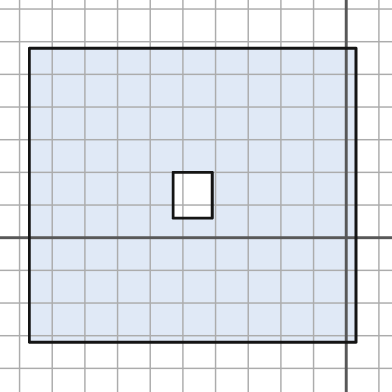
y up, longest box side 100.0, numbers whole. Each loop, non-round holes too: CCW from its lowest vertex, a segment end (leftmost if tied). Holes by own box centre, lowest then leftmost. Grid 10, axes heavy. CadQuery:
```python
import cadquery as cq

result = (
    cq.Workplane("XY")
    .moveTo(-97.0, -32.0)
    .lineTo(3.0, -32.0)
    .lineTo(3.0, 58.0)
    .lineTo(-97.0, 58.0)
    .close()
    .moveTo(-53.0, 6.0)
    .lineTo(-41.0, 6.0)
    .lineTo(-41.0, 20.0)
    .lineTo(-53.0, 20.0)
    .close()
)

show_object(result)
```